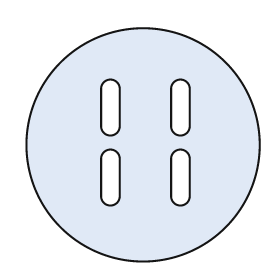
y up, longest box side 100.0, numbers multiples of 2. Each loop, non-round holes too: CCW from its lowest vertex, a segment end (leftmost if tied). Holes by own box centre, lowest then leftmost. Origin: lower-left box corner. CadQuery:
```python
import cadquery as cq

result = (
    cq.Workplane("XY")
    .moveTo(50.0, 50.0)
    .circle(50.0)
    .moveTo(32.0, 28.0)
    .threePointArc((36.0, 24.0), (40.0, 28.0))
    .lineTo(40.0, 44.0)
    .threePointArc((36.0, 48.0), (32.0, 44.0))
    .close()
    .moveTo(62.0, 28.0)
    .threePointArc((66.0, 24.0), (70.0, 28.0))
    .lineTo(70.0, 44.0)
    .threePointArc((66.0, 48.0), (62.0, 44.0))
    .close()
    .moveTo(32.0, 58.0)
    .threePointArc((36.0, 54.0), (40.0, 58.0))
    .lineTo(40.0, 74.0)
    .threePointArc((36.0, 78.0), (32.0, 74.0))
    .close()
    .moveTo(62.0, 58.0)
    .threePointArc((66.0, 54.0), (70.0, 58.0))
    .lineTo(70.0, 74.0)
    .threePointArc((66.0, 78.0), (62.0, 74.0))
    .close()
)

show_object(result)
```